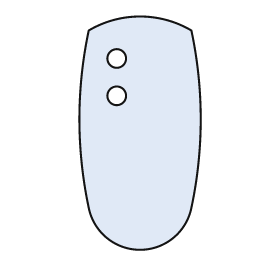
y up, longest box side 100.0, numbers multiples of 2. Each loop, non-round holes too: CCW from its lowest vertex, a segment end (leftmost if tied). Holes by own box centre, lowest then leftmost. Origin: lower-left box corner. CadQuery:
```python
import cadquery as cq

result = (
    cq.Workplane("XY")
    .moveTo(4.0, 18.0)
    .threePointArc((26.0, 0.0), (48.0, 18.0))
    .threePointArc((52.0, 56.0), (48.0, 94.0))
    .threePointArc((26.0, 100.0), (4.0, 94.0))
    .threePointArc((0.0, 56.0), (4.0, 18.0))
    .close()
    .moveTo(16.0, 66.0)
    .circle(4.0)
    .moveTo(16.0, 82.0)
    .circle(4.0)
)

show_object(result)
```